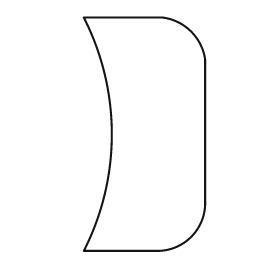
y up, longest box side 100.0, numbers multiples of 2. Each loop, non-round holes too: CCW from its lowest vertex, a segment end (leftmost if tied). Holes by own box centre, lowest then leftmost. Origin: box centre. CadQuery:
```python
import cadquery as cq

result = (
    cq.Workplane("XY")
    .moveTo(-26.0, -50.0)
    .lineTo(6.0, -50.0)
    .threePointArc((20.0, -44.0), (26.0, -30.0))
    .lineTo(26.0, 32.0)
    .threePointArc((20.0, 44.0), (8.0, 50.0))
    .lineTo(-26.0, 50.0)
    .threePointArc((-14.0, 0.0), (-26.0, -50.0))
    .close()
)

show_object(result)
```